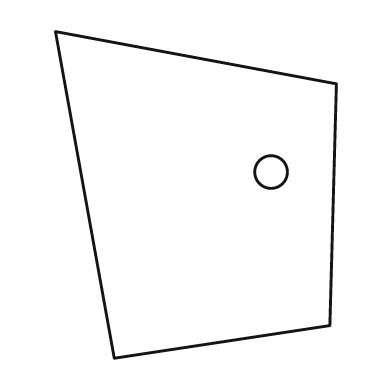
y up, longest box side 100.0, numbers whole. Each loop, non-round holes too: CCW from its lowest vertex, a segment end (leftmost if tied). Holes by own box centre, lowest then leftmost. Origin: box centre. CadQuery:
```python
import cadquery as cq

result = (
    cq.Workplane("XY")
    .moveTo(-25.0, -50.0)
    .lineTo(41.0, -40.0)
    .lineTo(43.0, 34.0)
    .lineTo(-43.0, 50.0)
    .close()
    .moveTo(23.0, 7.0)
    .circle(5.0)
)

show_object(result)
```